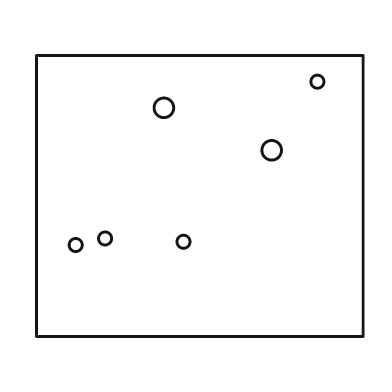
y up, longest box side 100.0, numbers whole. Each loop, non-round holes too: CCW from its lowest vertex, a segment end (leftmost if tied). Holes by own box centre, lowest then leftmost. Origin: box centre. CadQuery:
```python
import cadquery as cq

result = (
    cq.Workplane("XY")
    .moveTo(-50.0, -43.0)
    .lineTo(50.0, -43.0)
    .lineTo(50.0, 43.0)
    .lineTo(-50.0, 43.0)
    .close()
    .moveTo(-38.0, -15.0)
    .circle(2.0)
    .moveTo(-5.0, -14.0)
    .circle(2.0)
    .moveTo(-29.0, -13.0)
    .circle(2.0)
    .moveTo(22.0, 14.0)
    .circle(3.0)
    .moveTo(-11.0, 27.0)
    .circle(3.0)
    .moveTo(36.0, 35.0)
    .circle(2.0)
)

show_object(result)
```